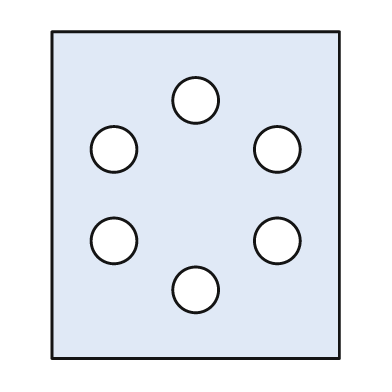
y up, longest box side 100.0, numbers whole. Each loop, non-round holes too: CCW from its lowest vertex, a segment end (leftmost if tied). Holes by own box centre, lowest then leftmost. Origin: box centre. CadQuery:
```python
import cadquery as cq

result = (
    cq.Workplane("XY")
    .moveTo(-44.0, -50.0)
    .lineTo(44.0, -50.0)
    .lineTo(44.0, 50.0)
    .lineTo(-44.0, 50.0)
    .close()
    .moveTo(0.0, -29.0)
    .circle(7.0)
    .moveTo(-25.0, -14.0)
    .circle(7.0)
    .moveTo(25.0, -14.0)
    .circle(7.0)
    .moveTo(-25.0, 14.0)
    .circle(7.0)
    .moveTo(25.0, 14.0)
    .circle(7.0)
    .moveTo(0.0, 29.0)
    .circle(7.0)
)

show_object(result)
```